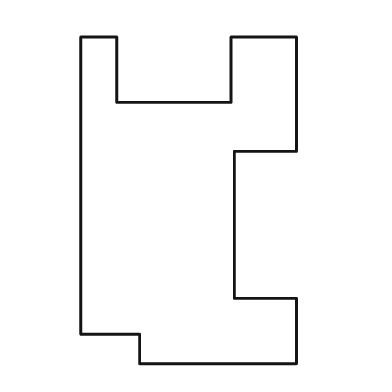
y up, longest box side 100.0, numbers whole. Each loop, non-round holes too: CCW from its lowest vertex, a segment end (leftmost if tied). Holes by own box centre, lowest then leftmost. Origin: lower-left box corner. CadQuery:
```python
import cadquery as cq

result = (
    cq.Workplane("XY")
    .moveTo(18.0, 0.0)
    .lineTo(66.0, 0.0)
    .lineTo(66.0, 20.0)
    .lineTo(47.0, 20.0)
    .lineTo(47.0, 65.0)
    .lineTo(66.0, 65.0)
    .lineTo(66.0, 100.0)
    .lineTo(46.0, 100.0)
    .lineTo(46.0, 80.0)
    .lineTo(11.0, 80.0)
    .lineTo(11.0, 100.0)
    .lineTo(0.0, 100.0)
    .lineTo(0.0, 9.0)
    .lineTo(18.0, 9.0)
    .close()
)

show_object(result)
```